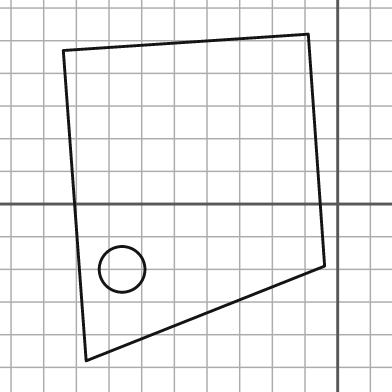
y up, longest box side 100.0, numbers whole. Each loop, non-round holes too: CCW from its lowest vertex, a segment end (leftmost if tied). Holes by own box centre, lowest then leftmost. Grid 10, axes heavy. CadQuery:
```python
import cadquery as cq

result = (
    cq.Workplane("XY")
    .moveTo(-77.0, -48.0)
    .lineTo(-4.0, -19.0)
    .lineTo(-9.0, 52.0)
    .lineTo(-84.0, 47.0)
    .close()
    .moveTo(-66.0, -20.0)
    .circle(7.0)
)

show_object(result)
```